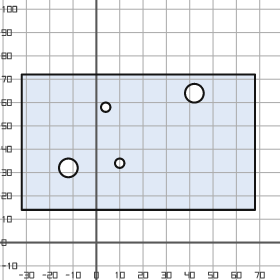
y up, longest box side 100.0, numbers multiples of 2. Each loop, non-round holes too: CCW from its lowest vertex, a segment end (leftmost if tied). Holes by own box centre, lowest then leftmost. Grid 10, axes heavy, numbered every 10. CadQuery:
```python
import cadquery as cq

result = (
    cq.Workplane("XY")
    .moveTo(-32.0, 14.0)
    .lineTo(68.0, 14.0)
    .lineTo(68.0, 72.0)
    .lineTo(-32.0, 72.0)
    .close()
    .moveTo(-12.0, 32.0)
    .circle(4.0)
    .moveTo(10.0, 34.0)
    .circle(2.0)
    .moveTo(4.0, 58.0)
    .circle(2.0)
    .moveTo(42.0, 64.0)
    .circle(4.0)
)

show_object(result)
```